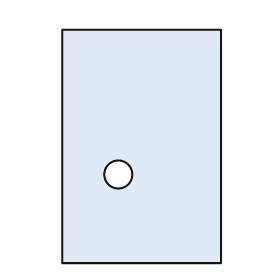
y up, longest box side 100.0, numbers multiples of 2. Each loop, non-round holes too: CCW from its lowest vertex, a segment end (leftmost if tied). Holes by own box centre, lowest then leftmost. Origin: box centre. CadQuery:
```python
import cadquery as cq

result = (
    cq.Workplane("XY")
    .moveTo(-34.0, -50.0)
    .lineTo(34.0, -50.0)
    .lineTo(34.0, 50.0)
    .lineTo(-34.0, 50.0)
    .close()
    .moveTo(-10.0, -12.0)
    .circle(6.0)
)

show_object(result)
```